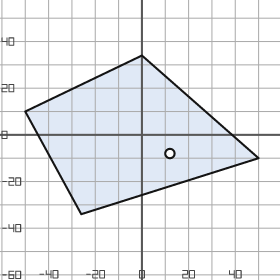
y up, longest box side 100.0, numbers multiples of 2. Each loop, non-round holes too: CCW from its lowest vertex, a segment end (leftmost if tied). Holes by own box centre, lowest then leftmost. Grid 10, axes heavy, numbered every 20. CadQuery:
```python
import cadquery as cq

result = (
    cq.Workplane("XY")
    .moveTo(-26.0, -34.0)
    .lineTo(50.0, -10.0)
    .lineTo(0.0, 34.0)
    .lineTo(-50.0, 10.0)
    .close()
    .moveTo(12.0, -8.0)
    .circle(2.0)
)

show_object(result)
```